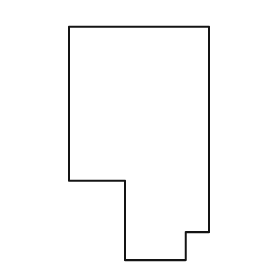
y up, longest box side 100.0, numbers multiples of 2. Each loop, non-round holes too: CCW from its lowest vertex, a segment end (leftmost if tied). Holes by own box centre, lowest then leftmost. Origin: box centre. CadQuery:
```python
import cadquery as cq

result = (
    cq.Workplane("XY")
    .moveTo(-6.0, -50.0)
    .lineTo(20.0, -50.0)
    .lineTo(20.0, -38.0)
    .lineTo(30.0, -38.0)
    .lineTo(30.0, 50.0)
    .lineTo(-30.0, 50.0)
    .lineTo(-30.0, -16.0)
    .lineTo(-6.0, -16.0)
    .close()
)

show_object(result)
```